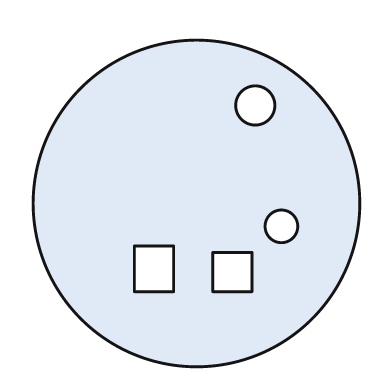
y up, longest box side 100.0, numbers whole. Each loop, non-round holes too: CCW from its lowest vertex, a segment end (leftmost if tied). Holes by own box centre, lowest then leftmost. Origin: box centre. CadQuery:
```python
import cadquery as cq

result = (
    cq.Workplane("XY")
    .moveTo(0.0, 0.0)
    .circle(50.0)
    .moveTo(5.0, -27.0)
    .lineTo(17.0, -27.0)
    .lineTo(17.0, -15.0)
    .lineTo(5.0, -15.0)
    .close()
    .moveTo(-19.0, -27.0)
    .lineTo(-7.0, -27.0)
    .lineTo(-7.0, -13.0)
    .lineTo(-19.0, -13.0)
    .close()
    .moveTo(26.0, -7.0)
    .circle(5.0)
    .moveTo(18.0, 30.0)
    .circle(6.0)
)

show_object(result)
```